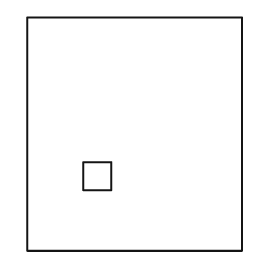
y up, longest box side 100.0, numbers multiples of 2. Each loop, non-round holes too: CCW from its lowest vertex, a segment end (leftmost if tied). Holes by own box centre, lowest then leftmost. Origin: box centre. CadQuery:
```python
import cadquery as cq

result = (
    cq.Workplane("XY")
    .moveTo(-46.0, -50.0)
    .lineTo(46.0, -50.0)
    .lineTo(46.0, 50.0)
    .lineTo(-46.0, 50.0)
    .close()
    .moveTo(-22.0, -24.0)
    .lineTo(-10.0, -24.0)
    .lineTo(-10.0, -12.0)
    .lineTo(-22.0, -12.0)
    .close()
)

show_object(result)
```